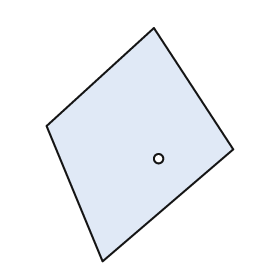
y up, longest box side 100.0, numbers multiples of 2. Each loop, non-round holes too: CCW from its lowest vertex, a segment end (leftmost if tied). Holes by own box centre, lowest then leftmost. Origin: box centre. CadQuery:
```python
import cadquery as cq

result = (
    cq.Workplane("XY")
    .moveTo(-16.0, -50.0)
    .lineTo(40.0, -2.0)
    .lineTo(6.0, 50.0)
    .lineTo(-40.0, 8.0)
    .close()
    .moveTo(8.0, -6.0)
    .circle(2.0)
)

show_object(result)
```